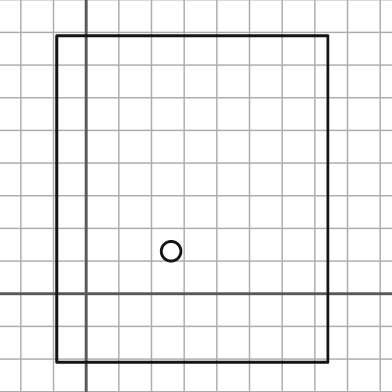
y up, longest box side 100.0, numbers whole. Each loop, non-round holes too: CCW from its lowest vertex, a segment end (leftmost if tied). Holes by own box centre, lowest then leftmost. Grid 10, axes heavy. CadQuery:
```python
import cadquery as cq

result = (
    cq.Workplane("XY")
    .moveTo(-9.0, -21.0)
    .lineTo(74.0, -21.0)
    .lineTo(74.0, 79.0)
    .lineTo(-9.0, 79.0)
    .close()
    .moveTo(26.0, 13.0)
    .circle(3.0)
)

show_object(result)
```